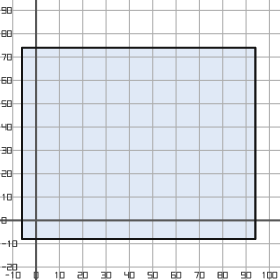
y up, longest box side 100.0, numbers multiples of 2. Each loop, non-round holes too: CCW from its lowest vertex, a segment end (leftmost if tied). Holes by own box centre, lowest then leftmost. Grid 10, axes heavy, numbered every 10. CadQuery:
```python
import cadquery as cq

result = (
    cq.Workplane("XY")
    .moveTo(-6.0, -8.0)
    .lineTo(94.0, -8.0)
    .lineTo(94.0, 74.0)
    .lineTo(-6.0, 74.0)
    .close()
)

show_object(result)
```